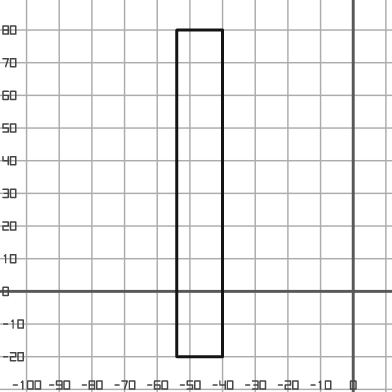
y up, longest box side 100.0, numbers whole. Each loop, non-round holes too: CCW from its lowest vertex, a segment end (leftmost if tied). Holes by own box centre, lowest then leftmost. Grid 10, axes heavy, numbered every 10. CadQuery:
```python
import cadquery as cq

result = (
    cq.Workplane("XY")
    .moveTo(-54.0, -20.0)
    .lineTo(-40.0, -20.0)
    .lineTo(-40.0, 80.0)
    .lineTo(-54.0, 80.0)
    .close()
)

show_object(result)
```